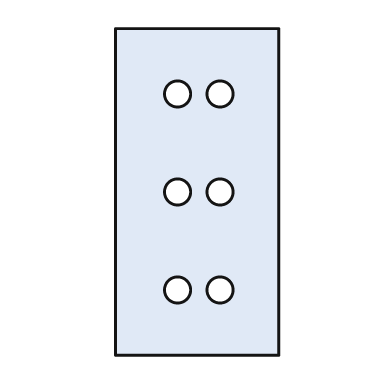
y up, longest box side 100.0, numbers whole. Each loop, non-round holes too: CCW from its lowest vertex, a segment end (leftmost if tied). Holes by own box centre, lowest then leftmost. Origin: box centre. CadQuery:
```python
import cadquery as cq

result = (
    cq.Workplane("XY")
    .moveTo(-25.0, -50.0)
    .lineTo(25.0, -50.0)
    .lineTo(25.0, 50.0)
    .lineTo(-25.0, 50.0)
    .close()
    .moveTo(-6.0, -30.0)
    .circle(4.0)
    .moveTo(7.0, -30.0)
    .circle(4.0)
    .moveTo(-6.0, 0.0)
    .circle(4.0)
    .moveTo(7.0, 0.0)
    .circle(4.0)
    .moveTo(-6.0, 30.0)
    .circle(4.0)
    .moveTo(7.0, 30.0)
    .circle(4.0)
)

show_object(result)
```